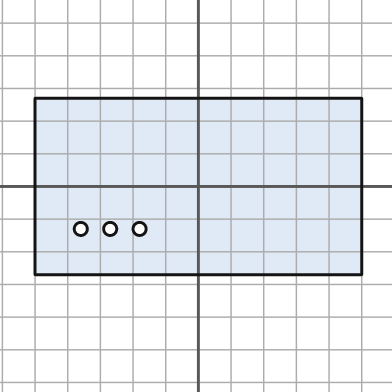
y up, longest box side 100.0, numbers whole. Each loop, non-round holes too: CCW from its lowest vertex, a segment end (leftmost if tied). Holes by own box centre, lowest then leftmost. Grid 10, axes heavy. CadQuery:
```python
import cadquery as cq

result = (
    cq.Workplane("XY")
    .moveTo(-50.0, -27.0)
    .lineTo(50.0, -27.0)
    .lineTo(50.0, 27.0)
    .lineTo(-50.0, 27.0)
    .close()
    .moveTo(-36.0, -13.0)
    .circle(2.0)
    .moveTo(-27.0, -13.0)
    .circle(2.0)
    .moveTo(-18.0, -13.0)
    .circle(2.0)
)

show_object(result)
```